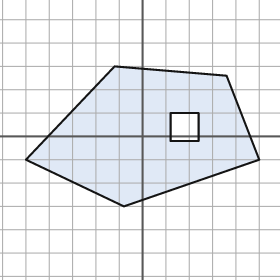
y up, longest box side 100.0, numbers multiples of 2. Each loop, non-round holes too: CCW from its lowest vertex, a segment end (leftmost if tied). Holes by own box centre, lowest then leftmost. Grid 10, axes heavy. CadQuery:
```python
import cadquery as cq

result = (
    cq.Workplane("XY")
    .moveTo(-8.0, -30.0)
    .lineTo(50.0, -10.0)
    .lineTo(36.0, 26.0)
    .lineTo(-12.0, 30.0)
    .lineTo(-50.0, -10.0)
    .close()
    .moveTo(12.0, -2.0)
    .lineTo(24.0, -2.0)
    .lineTo(24.0, 10.0)
    .lineTo(12.0, 10.0)
    .close()
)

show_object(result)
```